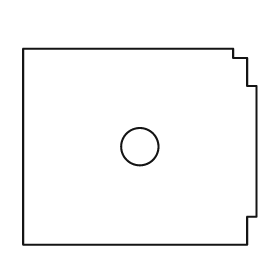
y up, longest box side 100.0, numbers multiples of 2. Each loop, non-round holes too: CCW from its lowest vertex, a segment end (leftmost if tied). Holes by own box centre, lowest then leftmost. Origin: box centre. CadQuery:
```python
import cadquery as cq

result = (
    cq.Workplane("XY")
    .moveTo(-50.0, -42.0)
    .lineTo(46.0, -42.0)
    .lineTo(46.0, -30.0)
    .lineTo(50.0, -30.0)
    .lineTo(50.0, 26.0)
    .lineTo(46.0, 26.0)
    .lineTo(46.0, 38.0)
    .lineTo(40.0, 38.0)
    .lineTo(40.0, 42.0)
    .lineTo(-50.0, 42.0)
    .close()
    .moveTo(0.0, 0.0)
    .circle(8.0)
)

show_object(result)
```